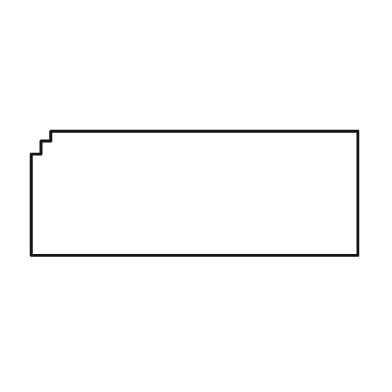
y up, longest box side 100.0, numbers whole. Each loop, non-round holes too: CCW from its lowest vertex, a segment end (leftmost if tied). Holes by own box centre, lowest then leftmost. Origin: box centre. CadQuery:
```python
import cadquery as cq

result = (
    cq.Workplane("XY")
    .moveTo(-50.0, -19.0)
    .lineTo(50.0, -19.0)
    .lineTo(50.0, 19.0)
    .lineTo(-44.0, 19.0)
    .lineTo(-44.0, 16.0)
    .lineTo(-47.0, 16.0)
    .lineTo(-47.0, 12.0)
    .lineTo(-50.0, 12.0)
    .close()
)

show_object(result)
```